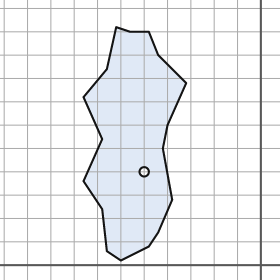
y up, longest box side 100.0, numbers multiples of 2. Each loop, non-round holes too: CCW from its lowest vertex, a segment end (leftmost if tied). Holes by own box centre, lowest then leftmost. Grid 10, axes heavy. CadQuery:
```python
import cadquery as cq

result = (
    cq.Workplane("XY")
    .moveTo(-60.0, 2.0)
    .lineTo(-48.0, 8.0)
    .lineTo(-44.0, 14.0)
    .lineTo(-38.0, 28.0)
    .lineTo(-42.0, 50.0)
    .lineTo(-40.0, 60.0)
    .lineTo(-32.0, 78.0)
    .lineTo(-44.0, 90.0)
    .lineTo(-48.0, 100.0)
    .lineTo(-56.0, 100.0)
    .lineTo(-62.0, 102.0)
    .lineTo(-66.0, 84.0)
    .lineTo(-76.0, 72.0)
    .lineTo(-68.0, 54.0)
    .lineTo(-76.0, 36.0)
    .lineTo(-68.0, 24.0)
    .lineTo(-66.0, 6.0)
    .close()
    .moveTo(-50.0, 40.0)
    .circle(2.0)
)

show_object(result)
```